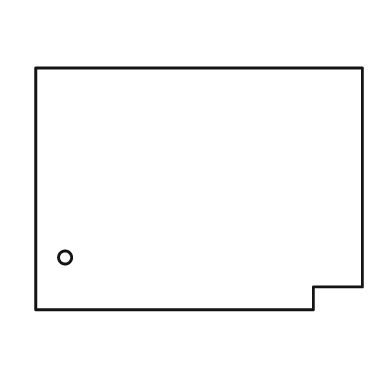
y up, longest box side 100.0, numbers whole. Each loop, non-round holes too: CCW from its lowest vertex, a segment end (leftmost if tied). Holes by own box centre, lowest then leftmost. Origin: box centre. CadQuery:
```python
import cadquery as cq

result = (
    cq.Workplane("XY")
    .moveTo(-50.0, -37.0)
    .lineTo(35.0, -37.0)
    .lineTo(35.0, -30.0)
    .lineTo(50.0, -30.0)
    .lineTo(50.0, 37.0)
    .lineTo(-50.0, 37.0)
    .close()
    .moveTo(-41.0, -21.0)
    .circle(2.0)
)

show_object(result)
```